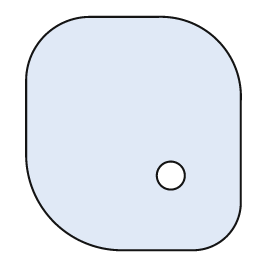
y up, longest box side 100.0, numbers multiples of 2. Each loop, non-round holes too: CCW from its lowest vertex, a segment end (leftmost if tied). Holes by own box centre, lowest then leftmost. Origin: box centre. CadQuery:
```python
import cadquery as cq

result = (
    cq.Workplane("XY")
    .moveTo(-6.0, -50.0)
    .lineTo(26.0, -50.0)
    .threePointArc((40.0, -44.0), (46.0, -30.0))
    .lineTo(46.0, 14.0)
    .threePointArc((36.0, 40.0), (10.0, 50.0))
    .lineTo(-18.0, 50.0)
    .threePointArc((-38.0, 42.0), (-46.0, 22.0))
    .lineTo(-46.0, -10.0)
    .threePointArc((-34.0, -38.0), (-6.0, -50.0))
    .close()
    .moveTo(16.0, -18.0)
    .circle(6.0)
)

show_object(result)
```